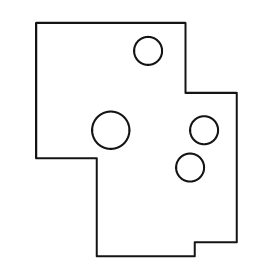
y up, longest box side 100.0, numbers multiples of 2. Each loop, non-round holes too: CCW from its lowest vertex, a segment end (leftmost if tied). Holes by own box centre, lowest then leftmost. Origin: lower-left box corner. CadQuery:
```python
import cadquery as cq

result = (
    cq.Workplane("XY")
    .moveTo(26.0, 0.0)
    .lineTo(68.0, 0.0)
    .lineTo(68.0, 6.0)
    .lineTo(86.0, 6.0)
    .lineTo(86.0, 70.0)
    .lineTo(64.0, 70.0)
    .lineTo(64.0, 100.0)
    .lineTo(0.0, 100.0)
    .lineTo(0.0, 42.0)
    .lineTo(26.0, 42.0)
    .close()
    .moveTo(66.0, 38.0)
    .circle(6.0)
    .moveTo(32.0, 54.0)
    .circle(8.0)
    .moveTo(72.0, 54.0)
    .circle(6.0)
    .moveTo(48.0, 88.0)
    .circle(6.0)
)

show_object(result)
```